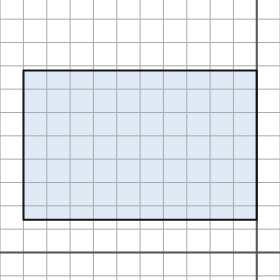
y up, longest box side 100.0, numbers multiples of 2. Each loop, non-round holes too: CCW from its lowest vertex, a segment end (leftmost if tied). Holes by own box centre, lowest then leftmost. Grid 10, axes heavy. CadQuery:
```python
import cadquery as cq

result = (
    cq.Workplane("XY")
    .moveTo(-100.0, 14.0)
    .lineTo(0.0, 14.0)
    .lineTo(0.0, 78.0)
    .lineTo(-100.0, 78.0)
    .close()
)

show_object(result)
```